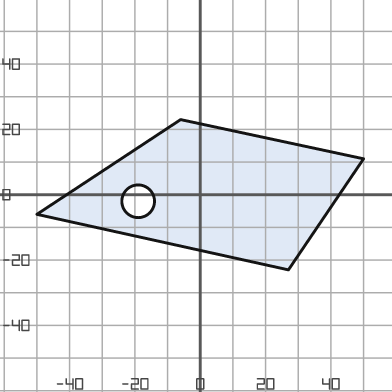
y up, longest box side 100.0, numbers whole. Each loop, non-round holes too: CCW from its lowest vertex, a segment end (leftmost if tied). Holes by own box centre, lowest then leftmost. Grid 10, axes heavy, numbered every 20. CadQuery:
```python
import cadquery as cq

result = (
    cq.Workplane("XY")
    .moveTo(27.0, -23.0)
    .lineTo(50.0, 11.0)
    .lineTo(-6.0, 23.0)
    .lineTo(-50.0, -6.0)
    .close()
    .moveTo(-19.0, -2.0)
    .circle(5.0)
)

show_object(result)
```